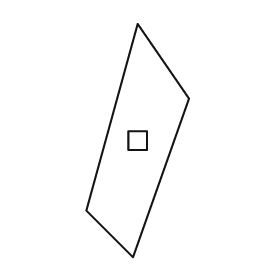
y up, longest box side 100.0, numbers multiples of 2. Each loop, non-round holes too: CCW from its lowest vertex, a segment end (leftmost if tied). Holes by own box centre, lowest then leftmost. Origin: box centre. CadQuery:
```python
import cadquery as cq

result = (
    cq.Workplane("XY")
    .moveTo(-2.0, -50.0)
    .lineTo(22.0, 18.0)
    .lineTo(0.0, 50.0)
    .lineTo(-22.0, -30.0)
    .close()
    .moveTo(-4.0, -4.0)
    .lineTo(4.0, -4.0)
    .lineTo(4.0, 4.0)
    .lineTo(-4.0, 4.0)
    .close()
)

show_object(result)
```